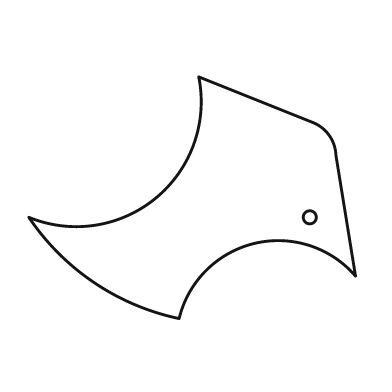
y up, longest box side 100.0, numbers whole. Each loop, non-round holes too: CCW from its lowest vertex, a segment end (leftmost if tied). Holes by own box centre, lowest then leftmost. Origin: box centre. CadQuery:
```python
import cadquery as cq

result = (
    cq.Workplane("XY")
    .moveTo(-4.0, -37.0)
    .threePointArc((19.0, -14.0), (50.0, -24.0))
    .lineTo(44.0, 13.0)
    .threePointArc((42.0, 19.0), (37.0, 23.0))
    .lineTo(2.0, 37.0)
    .threePointArc((-11.0, 0.0), (-50.0, -6.0))
    .threePointArc((-30.0, -26.0), (-4.0, -37.0))
    .close()
    .moveTo(36.0, -6.0)
    .circle(2.0)
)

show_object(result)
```